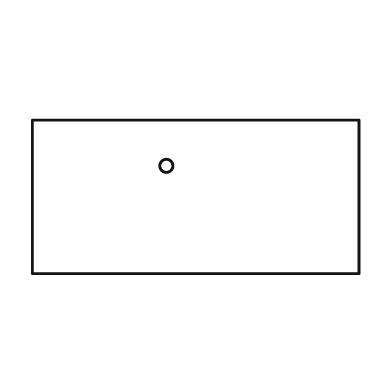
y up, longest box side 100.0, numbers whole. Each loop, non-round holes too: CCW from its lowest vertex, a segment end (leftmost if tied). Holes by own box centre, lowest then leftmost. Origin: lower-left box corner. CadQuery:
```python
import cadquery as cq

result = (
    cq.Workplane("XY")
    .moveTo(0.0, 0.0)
    .lineTo(100.0, 0.0)
    .lineTo(100.0, 47.0)
    .lineTo(0.0, 47.0)
    .close()
    .moveTo(41.0, 33.0)
    .circle(2.0)
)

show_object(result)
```